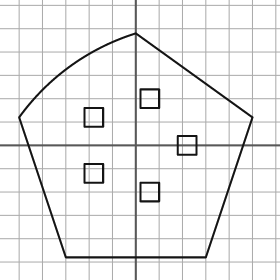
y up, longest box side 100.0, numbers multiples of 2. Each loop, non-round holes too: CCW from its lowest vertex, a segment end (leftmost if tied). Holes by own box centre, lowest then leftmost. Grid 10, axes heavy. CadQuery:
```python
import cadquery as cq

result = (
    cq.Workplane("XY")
    .moveTo(-30.0, -48.0)
    .lineTo(30.0, -48.0)
    .lineTo(50.0, 12.0)
    .lineTo(0.0, 48.0)
    .threePointArc((-28.0, 34.0), (-50.0, 12.0))
    .close()
    .moveTo(2.0, -24.0)
    .lineTo(10.0, -24.0)
    .lineTo(10.0, -16.0)
    .lineTo(2.0, -16.0)
    .close()
    .moveTo(-22.0, -16.0)
    .lineTo(-14.0, -16.0)
    .lineTo(-14.0, -8.0)
    .lineTo(-22.0, -8.0)
    .close()
    .moveTo(18.0, -4.0)
    .lineTo(26.0, -4.0)
    .lineTo(26.0, 4.0)
    .lineTo(18.0, 4.0)
    .close()
    .moveTo(-22.0, 8.0)
    .lineTo(-14.0, 8.0)
    .lineTo(-14.0, 16.0)
    .lineTo(-22.0, 16.0)
    .close()
    .moveTo(2.0, 16.0)
    .lineTo(10.0, 16.0)
    .lineTo(10.0, 24.0)
    .lineTo(2.0, 24.0)
    .close()
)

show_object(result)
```